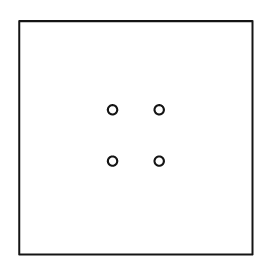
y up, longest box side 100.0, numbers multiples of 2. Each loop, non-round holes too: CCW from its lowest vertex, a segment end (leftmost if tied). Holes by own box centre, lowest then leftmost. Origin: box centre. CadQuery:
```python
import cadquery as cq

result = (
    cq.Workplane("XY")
    .moveTo(-50.0, -50.0)
    .lineTo(50.0, -50.0)
    .lineTo(50.0, 50.0)
    .lineTo(-50.0, 50.0)
    .close()
    .moveTo(-10.0, -10.0)
    .circle(2.0)
    .moveTo(10.0, -10.0)
    .circle(2.0)
    .moveTo(-10.0, 12.0)
    .circle(2.0)
    .moveTo(10.0, 12.0)
    .circle(2.0)
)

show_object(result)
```